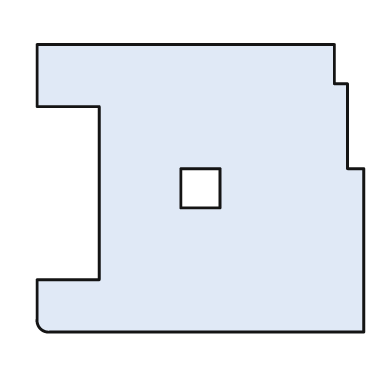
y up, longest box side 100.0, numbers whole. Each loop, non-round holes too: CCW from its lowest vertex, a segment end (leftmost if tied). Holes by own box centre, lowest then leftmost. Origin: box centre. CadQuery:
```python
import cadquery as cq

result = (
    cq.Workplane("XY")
    .moveTo(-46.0, -44.0)
    .lineTo(50.0, -44.0)
    .lineTo(50.0, 6.0)
    .lineTo(45.0, 6.0)
    .lineTo(45.0, 32.0)
    .lineTo(41.0, 32.0)
    .lineTo(41.0, 44.0)
    .lineTo(-50.0, 44.0)
    .lineTo(-50.0, 25.0)
    .lineTo(-31.0, 25.0)
    .lineTo(-31.0, -28.0)
    .lineTo(-50.0, -28.0)
    .lineTo(-50.0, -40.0)
    .threePointArc((-49.0, -43.0), (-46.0, -44.0))
    .close()
    .moveTo(-6.0, -6.0)
    .lineTo(6.0, -6.0)
    .lineTo(6.0, 6.0)
    .lineTo(-6.0, 6.0)
    .close()
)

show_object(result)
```